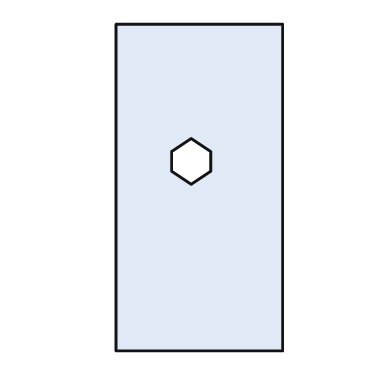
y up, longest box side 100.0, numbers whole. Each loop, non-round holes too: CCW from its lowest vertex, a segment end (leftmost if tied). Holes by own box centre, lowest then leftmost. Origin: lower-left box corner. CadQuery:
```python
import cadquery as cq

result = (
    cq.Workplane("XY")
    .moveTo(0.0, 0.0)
    .lineTo(51.0, 0.0)
    .lineTo(51.0, 100.0)
    .lineTo(0.0, 100.0)
    .close()
    .moveTo(23.0, 51.0)
    .lineTo(29.0, 55.0)
    .lineTo(29.0, 61.0)
    .lineTo(23.0, 65.0)
    .lineTo(17.0, 61.0)
    .lineTo(17.0, 55.0)
    .close()
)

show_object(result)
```